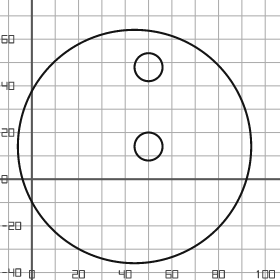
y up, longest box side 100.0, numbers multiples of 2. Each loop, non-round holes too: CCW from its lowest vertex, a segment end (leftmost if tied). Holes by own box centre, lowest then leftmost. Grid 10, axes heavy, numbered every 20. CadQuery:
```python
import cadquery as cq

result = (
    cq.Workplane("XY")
    .moveTo(44.0, 14.0)
    .circle(50.0)
    .moveTo(50.0, 14.0)
    .circle(6.0)
    .moveTo(50.0, 48.0)
    .circle(6.0)
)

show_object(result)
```